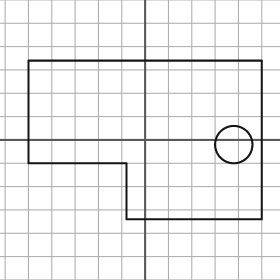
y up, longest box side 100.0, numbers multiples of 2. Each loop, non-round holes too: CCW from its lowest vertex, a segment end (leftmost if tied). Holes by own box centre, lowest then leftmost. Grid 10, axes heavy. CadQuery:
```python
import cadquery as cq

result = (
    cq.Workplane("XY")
    .moveTo(-8.0, -34.0)
    .lineTo(50.0, -34.0)
    .lineTo(50.0, 34.0)
    .lineTo(-50.0, 34.0)
    .lineTo(-50.0, -10.0)
    .lineTo(-8.0, -10.0)
    .close()
    .moveTo(38.0, -2.0)
    .circle(8.0)
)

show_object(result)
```